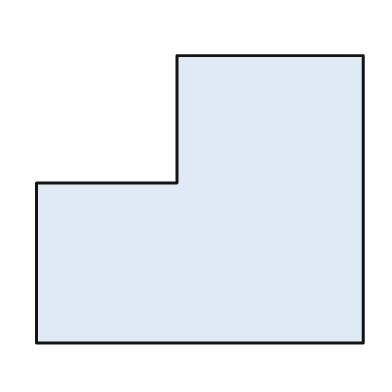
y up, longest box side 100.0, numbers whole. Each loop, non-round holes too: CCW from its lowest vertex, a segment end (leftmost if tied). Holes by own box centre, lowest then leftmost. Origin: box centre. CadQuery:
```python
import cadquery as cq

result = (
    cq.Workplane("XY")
    .moveTo(-50.0, -44.0)
    .lineTo(50.0, -44.0)
    .lineTo(50.0, 44.0)
    .lineTo(-7.0, 44.0)
    .lineTo(-7.0, 5.0)
    .lineTo(-50.0, 5.0)
    .close()
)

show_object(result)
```